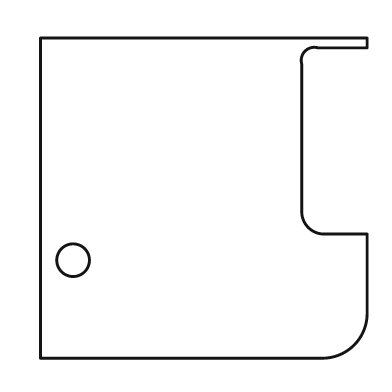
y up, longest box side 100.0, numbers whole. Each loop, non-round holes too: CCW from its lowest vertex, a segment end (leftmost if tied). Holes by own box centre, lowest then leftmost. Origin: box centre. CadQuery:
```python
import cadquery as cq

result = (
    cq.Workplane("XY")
    .moveTo(-50.0, -49.0)
    .lineTo(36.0, -49.0)
    .threePointArc((46.0, -45.0), (50.0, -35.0))
    .lineTo(50.0, -11.0)
    .lineTo(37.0, -11.0)
    .threePointArc((32.0, -9.0), (30.0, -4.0))
    .lineTo(30.0, 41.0)
    .threePointArc((31.0, 45.0), (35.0, 46.0))
    .lineTo(50.0, 46.0)
    .lineTo(50.0, 49.0)
    .lineTo(-50.0, 49.0)
    .close()
    .moveTo(-40.0, -19.0)
    .circle(5.0)
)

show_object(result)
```